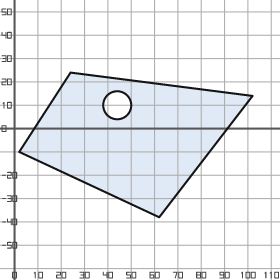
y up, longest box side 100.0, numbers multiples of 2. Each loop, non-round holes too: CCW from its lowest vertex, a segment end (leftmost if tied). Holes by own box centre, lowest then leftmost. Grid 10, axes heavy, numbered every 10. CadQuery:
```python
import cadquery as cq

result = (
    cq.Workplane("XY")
    .moveTo(62.0, -38.0)
    .lineTo(102.0, 14.0)
    .lineTo(24.0, 24.0)
    .lineTo(2.0, -10.0)
    .close()
    .moveTo(44.0, 10.0)
    .circle(6.0)
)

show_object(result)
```